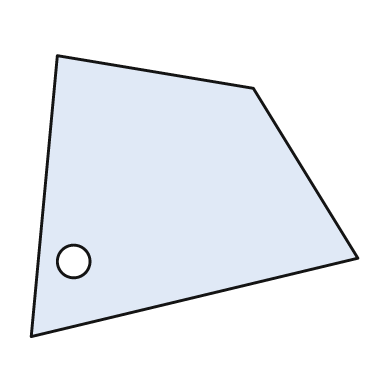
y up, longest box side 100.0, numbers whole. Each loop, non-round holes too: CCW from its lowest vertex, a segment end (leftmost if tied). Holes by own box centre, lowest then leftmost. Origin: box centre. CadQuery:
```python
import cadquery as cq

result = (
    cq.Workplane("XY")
    .moveTo(-50.0, -43.0)
    .lineTo(50.0, -19.0)
    .lineTo(18.0, 33.0)
    .lineTo(-42.0, 43.0)
    .close()
    .moveTo(-37.0, -20.0)
    .circle(5.0)
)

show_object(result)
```